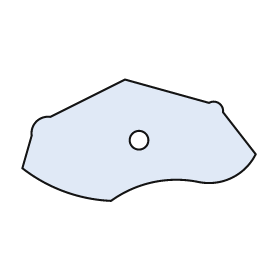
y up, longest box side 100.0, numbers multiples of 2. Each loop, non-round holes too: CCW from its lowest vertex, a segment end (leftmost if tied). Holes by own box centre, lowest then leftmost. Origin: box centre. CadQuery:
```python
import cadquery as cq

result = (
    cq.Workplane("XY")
    .moveTo(-12.0, -26.0)
    .threePointArc((6.0, -18.0), (26.0, -18.0))
    .threePointArc((40.0, -16.0), (50.0, -6.0))
    .lineTo(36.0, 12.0)
    .threePointArc((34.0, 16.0), (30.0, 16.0))
    .lineTo(-6.0, 26.0)
    .lineTo(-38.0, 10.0)
    .threePointArc((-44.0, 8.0), (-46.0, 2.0))
    .lineTo(-50.0, -12.0)
    .threePointArc((-32.0, -22.0), (-12.0, -26.0))
    .close()
    .moveTo(0.0, 0.0)
    .circle(4.0)
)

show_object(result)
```